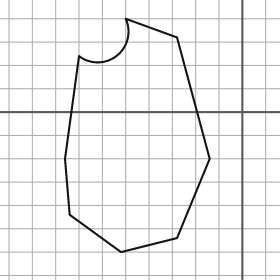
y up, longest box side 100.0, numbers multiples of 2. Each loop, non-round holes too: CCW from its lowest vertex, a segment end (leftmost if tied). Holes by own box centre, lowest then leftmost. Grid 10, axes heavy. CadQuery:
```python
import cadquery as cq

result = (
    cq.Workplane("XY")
    .moveTo(-52.0, -60.0)
    .lineTo(-28.0, -54.0)
    .lineTo(-14.0, -20.0)
    .lineTo(-28.0, 32.0)
    .lineTo(-50.0, 40.0)
    .threePointArc((-54.0, 24.0), (-70.0, 24.0))
    .lineTo(-76.0, -20.0)
    .lineTo(-74.0, -44.0)
    .close()
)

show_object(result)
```